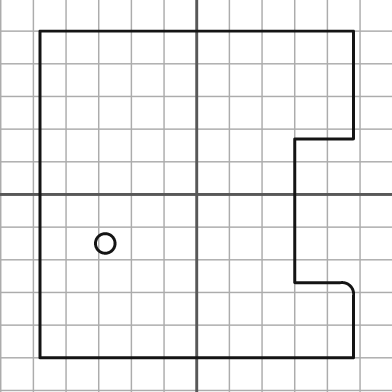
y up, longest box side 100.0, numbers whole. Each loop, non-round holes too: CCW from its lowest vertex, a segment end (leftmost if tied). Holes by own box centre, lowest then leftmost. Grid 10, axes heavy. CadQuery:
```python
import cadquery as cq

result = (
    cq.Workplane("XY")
    .moveTo(-48.0, -50.0)
    .lineTo(48.0, -50.0)
    .lineTo(48.0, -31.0)
    .threePointArc((47.0, -28.0), (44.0, -27.0))
    .lineTo(30.0, -27.0)
    .lineTo(30.0, 17.0)
    .lineTo(48.0, 17.0)
    .lineTo(48.0, 50.0)
    .lineTo(-48.0, 50.0)
    .close()
    .moveTo(-28.0, -15.0)
    .circle(3.0)
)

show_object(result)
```